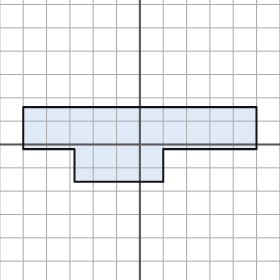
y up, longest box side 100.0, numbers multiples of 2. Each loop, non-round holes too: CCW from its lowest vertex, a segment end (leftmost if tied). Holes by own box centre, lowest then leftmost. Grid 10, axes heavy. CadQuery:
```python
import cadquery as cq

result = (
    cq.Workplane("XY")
    .moveTo(-28.0, -16.0)
    .lineTo(10.0, -16.0)
    .lineTo(10.0, -2.0)
    .lineTo(50.0, -2.0)
    .lineTo(50.0, 16.0)
    .lineTo(-50.0, 16.0)
    .lineTo(-50.0, -2.0)
    .lineTo(-28.0, -2.0)
    .close()
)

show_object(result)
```